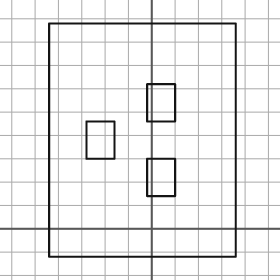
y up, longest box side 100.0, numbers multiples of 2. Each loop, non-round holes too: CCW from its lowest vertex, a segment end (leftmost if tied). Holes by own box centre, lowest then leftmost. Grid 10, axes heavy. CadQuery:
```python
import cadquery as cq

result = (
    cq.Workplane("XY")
    .moveTo(-44.0, -12.0)
    .lineTo(36.0, -12.0)
    .lineTo(36.0, 88.0)
    .lineTo(-44.0, 88.0)
    .close()
    .moveTo(-2.0, 14.0)
    .lineTo(10.0, 14.0)
    .lineTo(10.0, 30.0)
    .lineTo(-2.0, 30.0)
    .close()
    .moveTo(-28.0, 30.0)
    .lineTo(-16.0, 30.0)
    .lineTo(-16.0, 46.0)
    .lineTo(-28.0, 46.0)
    .close()
    .moveTo(-2.0, 46.0)
    .lineTo(10.0, 46.0)
    .lineTo(10.0, 62.0)
    .lineTo(-2.0, 62.0)
    .close()
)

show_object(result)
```